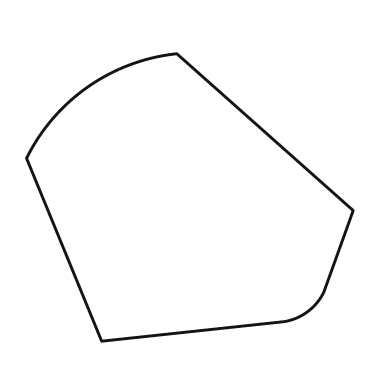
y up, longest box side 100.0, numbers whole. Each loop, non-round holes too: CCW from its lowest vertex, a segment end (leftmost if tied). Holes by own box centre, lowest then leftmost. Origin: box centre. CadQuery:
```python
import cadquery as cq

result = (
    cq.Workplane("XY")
    .moveTo(-27.0, -44.0)
    .lineTo(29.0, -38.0)
    .threePointArc((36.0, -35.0), (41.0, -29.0))
    .lineTo(50.0, -4.0)
    .lineTo(-4.0, 44.0)
    .threePointArc((-31.0, 34.0), (-50.0, 12.0))
    .close()
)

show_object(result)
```